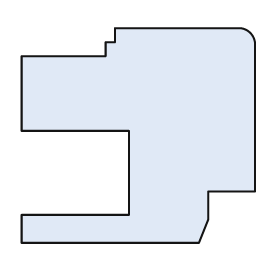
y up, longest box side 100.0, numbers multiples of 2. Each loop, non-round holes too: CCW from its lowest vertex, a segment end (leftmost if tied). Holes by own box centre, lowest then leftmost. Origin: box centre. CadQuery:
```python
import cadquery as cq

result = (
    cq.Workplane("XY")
    .moveTo(-50.0, -46.0)
    .lineTo(26.0, -46.0)
    .lineTo(30.0, -36.0)
    .lineTo(30.0, -24.0)
    .lineTo(50.0, -24.0)
    .lineTo(50.0, 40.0)
    .threePointArc((48.0, 44.0), (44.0, 46.0))
    .lineTo(-10.0, 46.0)
    .lineTo(-10.0, 40.0)
    .lineTo(-14.0, 40.0)
    .lineTo(-14.0, 34.0)
    .lineTo(-50.0, 34.0)
    .lineTo(-50.0, 2.0)
    .lineTo(-4.0, 2.0)
    .lineTo(-4.0, -34.0)
    .lineTo(-50.0, -34.0)
    .close()
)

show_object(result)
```